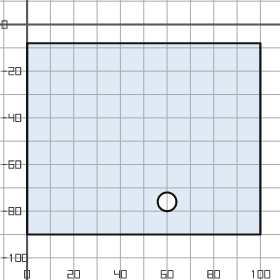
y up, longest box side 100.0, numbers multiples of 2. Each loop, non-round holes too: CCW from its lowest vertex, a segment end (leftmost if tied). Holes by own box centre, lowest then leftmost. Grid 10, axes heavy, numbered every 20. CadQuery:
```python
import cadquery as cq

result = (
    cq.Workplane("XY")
    .moveTo(0.0, -90.0)
    .lineTo(100.0, -90.0)
    .lineTo(100.0, -8.0)
    .lineTo(0.0, -8.0)
    .close()
    .moveTo(60.0, -76.0)
    .circle(4.0)
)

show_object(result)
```